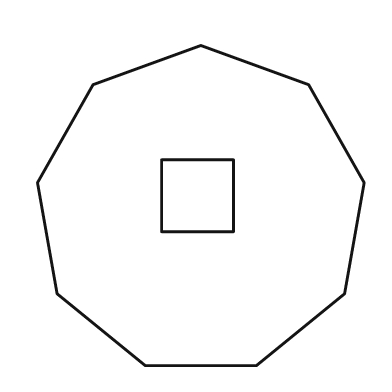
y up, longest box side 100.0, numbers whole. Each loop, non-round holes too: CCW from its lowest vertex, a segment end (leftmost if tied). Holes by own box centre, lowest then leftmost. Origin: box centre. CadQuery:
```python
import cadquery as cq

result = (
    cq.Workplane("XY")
    .moveTo(-17.0, -49.0)
    .lineTo(17.0, -49.0)
    .lineTo(44.0, -27.0)
    .lineTo(50.0, 7.0)
    .lineTo(33.0, 37.0)
    .lineTo(0.0, 49.0)
    .lineTo(-33.0, 37.0)
    .lineTo(-50.0, 7.0)
    .lineTo(-44.0, -27.0)
    .close()
    .moveTo(-12.0, -8.0)
    .lineTo(10.0, -8.0)
    .lineTo(10.0, 14.0)
    .lineTo(-12.0, 14.0)
    .close()
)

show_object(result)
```